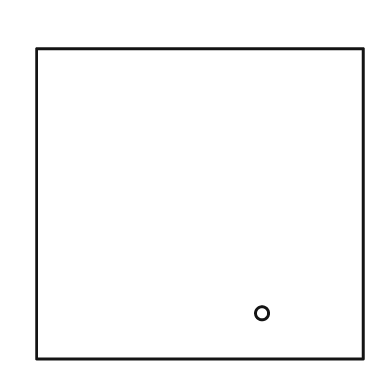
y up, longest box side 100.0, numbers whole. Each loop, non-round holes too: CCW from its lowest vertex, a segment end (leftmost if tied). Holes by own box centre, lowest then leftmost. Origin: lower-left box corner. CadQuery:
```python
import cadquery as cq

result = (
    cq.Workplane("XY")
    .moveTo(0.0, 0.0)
    .lineTo(100.0, 0.0)
    .lineTo(100.0, 95.0)
    .lineTo(0.0, 95.0)
    .close()
    .moveTo(69.0, 14.0)
    .circle(2.0)
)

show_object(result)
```